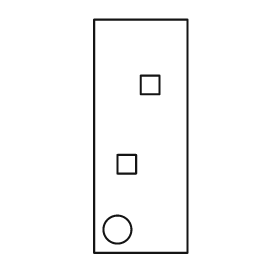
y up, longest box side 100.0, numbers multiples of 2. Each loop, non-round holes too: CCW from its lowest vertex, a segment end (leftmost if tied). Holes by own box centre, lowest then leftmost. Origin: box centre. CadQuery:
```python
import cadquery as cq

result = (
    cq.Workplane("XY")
    .moveTo(-20.0, -50.0)
    .lineTo(20.0, -50.0)
    .lineTo(20.0, 50.0)
    .lineTo(-20.0, 50.0)
    .close()
    .moveTo(-10.0, -40.0)
    .circle(6.0)
    .moveTo(-10.0, -16.0)
    .lineTo(-2.0, -16.0)
    .lineTo(-2.0, -8.0)
    .lineTo(-10.0, -8.0)
    .close()
    .moveTo(0.0, 18.0)
    .lineTo(8.0, 18.0)
    .lineTo(8.0, 26.0)
    .lineTo(0.0, 26.0)
    .close()
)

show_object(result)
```